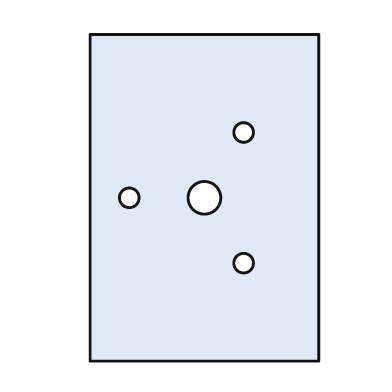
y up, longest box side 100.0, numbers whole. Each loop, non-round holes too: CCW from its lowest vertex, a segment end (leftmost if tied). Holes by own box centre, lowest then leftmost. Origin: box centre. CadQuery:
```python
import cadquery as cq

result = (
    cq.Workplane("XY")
    .moveTo(-35.0, -50.0)
    .lineTo(35.0, -50.0)
    .lineTo(35.0, 50.0)
    .lineTo(-35.0, 50.0)
    .close()
    .moveTo(12.0, -20.0)
    .circle(3.0)
    .moveTo(-23.0, 0.0)
    .circle(3.0)
    .moveTo(0.0, 0.0)
    .circle(5.0)
    .moveTo(12.0, 20.0)
    .circle(3.0)
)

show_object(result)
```